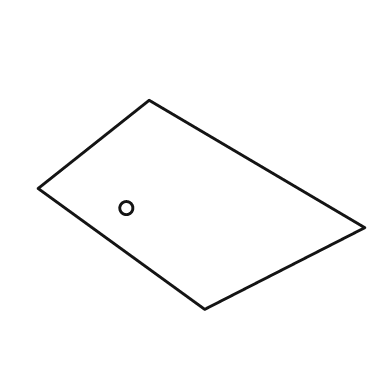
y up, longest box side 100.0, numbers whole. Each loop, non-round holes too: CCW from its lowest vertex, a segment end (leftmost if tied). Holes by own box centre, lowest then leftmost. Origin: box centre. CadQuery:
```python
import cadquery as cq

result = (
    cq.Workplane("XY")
    .moveTo(1.0, -32.0)
    .lineTo(50.0, -7.0)
    .lineTo(-16.0, 32.0)
    .lineTo(-50.0, 5.0)
    .close()
    .moveTo(-23.0, -1.0)
    .circle(2.0)
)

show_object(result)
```